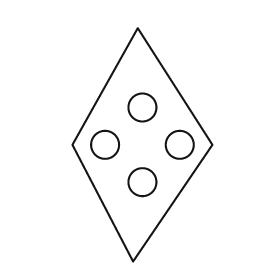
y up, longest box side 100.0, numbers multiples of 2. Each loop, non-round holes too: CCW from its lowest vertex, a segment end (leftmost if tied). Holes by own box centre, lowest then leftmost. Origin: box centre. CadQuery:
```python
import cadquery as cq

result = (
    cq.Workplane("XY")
    .moveTo(-4.0, -50.0)
    .lineTo(30.0, 0.0)
    .lineTo(-2.0, 50.0)
    .lineTo(-30.0, 0.0)
    .close()
    .moveTo(0.0, -16.0)
    .circle(6.0)
    .moveTo(-16.0, 0.0)
    .circle(6.0)
    .moveTo(16.0, 0.0)
    .circle(6.0)
    .moveTo(0.0, 16.0)
    .circle(6.0)
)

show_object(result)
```